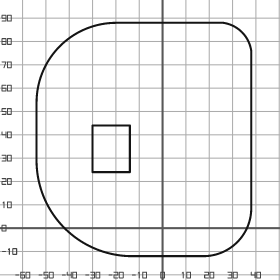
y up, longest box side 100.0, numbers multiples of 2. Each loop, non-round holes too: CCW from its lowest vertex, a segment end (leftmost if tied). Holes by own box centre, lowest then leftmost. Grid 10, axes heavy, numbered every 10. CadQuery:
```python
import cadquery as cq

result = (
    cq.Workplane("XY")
    .moveTo(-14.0, -12.0)
    .lineTo(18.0, -12.0)
    .threePointArc((32.0, -6.0), (38.0, 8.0))
    .lineTo(38.0, 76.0)
    .threePointArc((34.0, 84.0), (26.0, 88.0))
    .lineTo(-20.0, 88.0)
    .threePointArc((-44.0, 78.0), (-54.0, 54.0))
    .lineTo(-54.0, 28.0)
    .threePointArc((-42.0, 0.0), (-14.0, -12.0))
    .close()
    .moveTo(-30.0, 24.0)
    .lineTo(-14.0, 24.0)
    .lineTo(-14.0, 44.0)
    .lineTo(-30.0, 44.0)
    .close()
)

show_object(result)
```